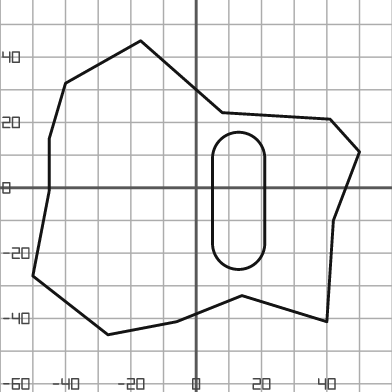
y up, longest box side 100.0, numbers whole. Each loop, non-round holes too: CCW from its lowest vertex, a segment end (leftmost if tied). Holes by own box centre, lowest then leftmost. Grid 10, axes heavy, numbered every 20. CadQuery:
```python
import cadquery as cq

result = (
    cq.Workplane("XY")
    .moveTo(-27.0, -45.0)
    .lineTo(-6.0, -41.0)
    .lineTo(14.0, -33.0)
    .lineTo(40.0, -41.0)
    .lineTo(42.0, -10.0)
    .lineTo(50.0, 11.0)
    .lineTo(41.0, 21.0)
    .lineTo(8.0, 23.0)
    .lineTo(-17.0, 45.0)
    .lineTo(-40.0, 32.0)
    .lineTo(-45.0, 15.0)
    .lineTo(-45.0, -1.0)
    .lineTo(-50.0, -27.0)
    .close()
    .moveTo(5.0, -17.0)
    .threePointArc((13.0, -25.0), (21.0, -17.0))
    .lineTo(21.0, 9.0)
    .threePointArc((13.0, 17.0), (5.0, 9.0))
    .close()
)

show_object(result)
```